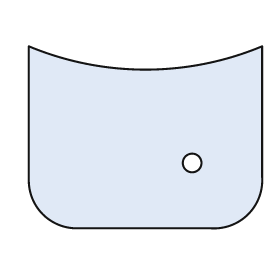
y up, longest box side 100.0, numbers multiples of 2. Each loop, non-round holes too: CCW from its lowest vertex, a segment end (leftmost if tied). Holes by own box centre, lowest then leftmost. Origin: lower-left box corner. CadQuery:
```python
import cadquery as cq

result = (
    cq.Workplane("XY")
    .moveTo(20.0, 0.0)
    .lineTo(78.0, 0.0)
    .threePointArc((94.0, 6.0), (100.0, 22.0))
    .lineTo(100.0, 78.0)
    .threePointArc((50.0, 68.0), (0.0, 78.0))
    .lineTo(0.0, 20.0)
    .threePointArc((6.0, 6.0), (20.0, 0.0))
    .close()
    .moveTo(70.0, 28.0)
    .circle(4.0)
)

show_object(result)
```